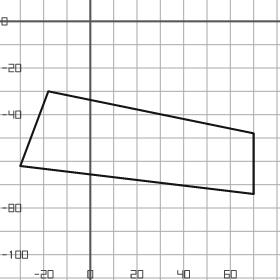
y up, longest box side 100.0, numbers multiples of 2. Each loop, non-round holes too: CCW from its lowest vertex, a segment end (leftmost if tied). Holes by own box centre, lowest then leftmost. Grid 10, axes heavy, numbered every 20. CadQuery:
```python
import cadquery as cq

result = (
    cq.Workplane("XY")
    .moveTo(70.0, -74.0)
    .lineTo(70.0, -48.0)
    .lineTo(-18.0, -30.0)
    .lineTo(-30.0, -62.0)
    .close()
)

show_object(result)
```